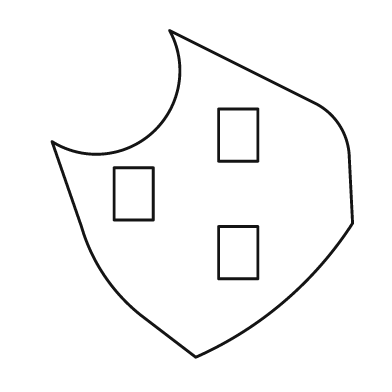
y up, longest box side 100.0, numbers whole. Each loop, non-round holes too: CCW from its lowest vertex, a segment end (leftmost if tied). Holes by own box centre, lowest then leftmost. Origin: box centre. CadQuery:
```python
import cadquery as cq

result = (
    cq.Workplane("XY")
    .moveTo(-2.0, -50.0)
    .threePointArc((25.0, -33.0), (46.0, -9.0))
    .lineTo(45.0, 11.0)
    .threePointArc((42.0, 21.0), (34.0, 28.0))
    .lineTo(-10.0, 50.0)
    .threePointArc((-15.0, 19.0), (-46.0, 16.0))
    .lineTo(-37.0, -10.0)
    .threePointArc((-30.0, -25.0), (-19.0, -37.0))
    .close()
    .moveTo(5.0, -26.0)
    .lineTo(17.0, -26.0)
    .lineTo(17.0, -10.0)
    .lineTo(5.0, -10.0)
    .close()
    .moveTo(-27.0, -8.0)
    .lineTo(-15.0, -8.0)
    .lineTo(-15.0, 8.0)
    .lineTo(-27.0, 8.0)
    .close()
    .moveTo(5.0, 10.0)
    .lineTo(17.0, 10.0)
    .lineTo(17.0, 26.0)
    .lineTo(5.0, 26.0)
    .close()
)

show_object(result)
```